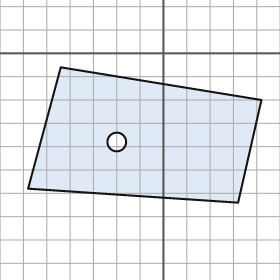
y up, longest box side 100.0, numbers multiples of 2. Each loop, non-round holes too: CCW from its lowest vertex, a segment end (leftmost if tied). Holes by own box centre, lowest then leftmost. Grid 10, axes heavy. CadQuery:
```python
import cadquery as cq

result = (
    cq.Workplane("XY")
    .moveTo(32.0, -64.0)
    .lineTo(42.0, -20.0)
    .lineTo(-44.0, -6.0)
    .lineTo(-58.0, -58.0)
    .close()
    .moveTo(-20.0, -38.0)
    .circle(4.0)
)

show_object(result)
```